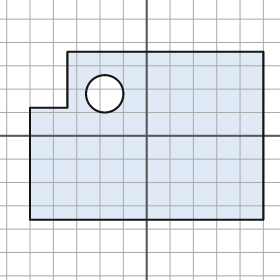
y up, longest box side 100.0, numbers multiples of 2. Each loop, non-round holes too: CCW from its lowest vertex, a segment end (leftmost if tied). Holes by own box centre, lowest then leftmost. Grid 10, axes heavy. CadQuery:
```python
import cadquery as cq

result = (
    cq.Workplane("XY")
    .moveTo(-50.0, -36.0)
    .lineTo(50.0, -36.0)
    .lineTo(50.0, 36.0)
    .lineTo(-34.0, 36.0)
    .lineTo(-34.0, 12.0)
    .lineTo(-50.0, 12.0)
    .close()
    .moveTo(-18.0, 18.0)
    .circle(8.0)
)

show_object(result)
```